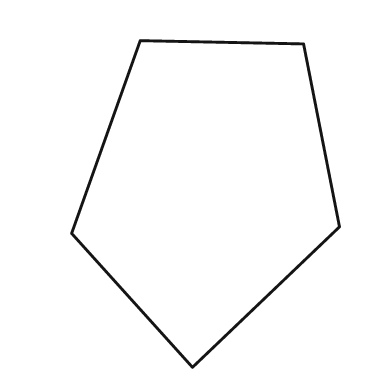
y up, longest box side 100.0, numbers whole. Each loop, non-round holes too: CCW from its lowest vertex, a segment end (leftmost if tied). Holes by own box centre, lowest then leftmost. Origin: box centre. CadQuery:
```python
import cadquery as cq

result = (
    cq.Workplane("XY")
    .moveTo(-4.0, -50.0)
    .lineTo(41.0, -7.0)
    .lineTo(30.0, 49.0)
    .lineTo(-20.0, 50.0)
    .lineTo(-41.0, -9.0)
    .close()
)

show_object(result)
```